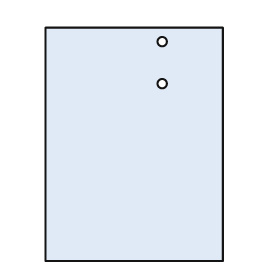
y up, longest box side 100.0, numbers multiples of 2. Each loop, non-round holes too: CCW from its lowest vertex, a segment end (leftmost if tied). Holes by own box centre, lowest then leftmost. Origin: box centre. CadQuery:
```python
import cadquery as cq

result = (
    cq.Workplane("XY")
    .moveTo(-38.0, -50.0)
    .lineTo(38.0, -50.0)
    .lineTo(38.0, 50.0)
    .lineTo(-38.0, 50.0)
    .close()
    .moveTo(12.0, 26.0)
    .circle(2.0)
    .moveTo(12.0, 44.0)
    .circle(2.0)
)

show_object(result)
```